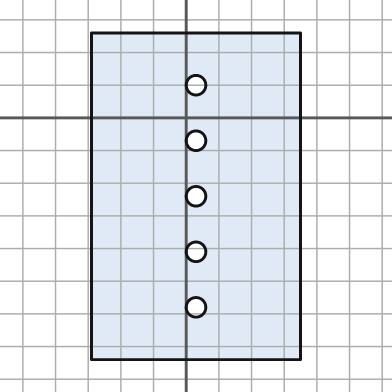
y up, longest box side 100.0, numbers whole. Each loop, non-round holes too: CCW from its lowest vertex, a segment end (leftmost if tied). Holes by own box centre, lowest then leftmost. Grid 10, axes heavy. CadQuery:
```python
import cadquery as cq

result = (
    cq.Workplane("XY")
    .moveTo(-29.0, -74.0)
    .lineTo(35.0, -74.0)
    .lineTo(35.0, 26.0)
    .lineTo(-29.0, 26.0)
    .close()
    .moveTo(3.0, -58.0)
    .circle(3.0)
    .moveTo(3.0, -41.0)
    .circle(3.0)
    .moveTo(3.0, -24.0)
    .circle(3.0)
    .moveTo(3.0, -7.0)
    .circle(3.0)
    .moveTo(3.0, 10.0)
    .circle(3.0)
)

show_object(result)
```